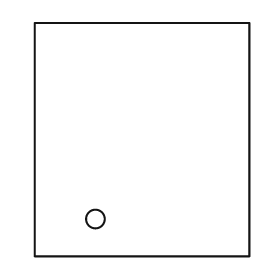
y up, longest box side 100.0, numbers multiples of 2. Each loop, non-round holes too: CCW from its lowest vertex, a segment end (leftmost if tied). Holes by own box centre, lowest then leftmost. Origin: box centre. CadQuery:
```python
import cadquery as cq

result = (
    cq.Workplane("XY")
    .moveTo(-46.0, -50.0)
    .lineTo(46.0, -50.0)
    .lineTo(46.0, 50.0)
    .lineTo(-46.0, 50.0)
    .close()
    .moveTo(-20.0, -34.0)
    .circle(4.0)
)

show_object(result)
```